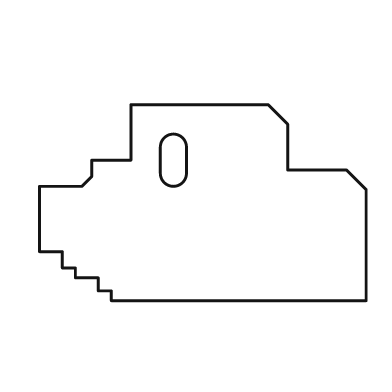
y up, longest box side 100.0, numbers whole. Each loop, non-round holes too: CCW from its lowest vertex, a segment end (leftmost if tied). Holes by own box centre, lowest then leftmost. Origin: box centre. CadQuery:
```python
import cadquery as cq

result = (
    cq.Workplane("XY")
    .moveTo(-28.0, -30.0)
    .lineTo(50.0, -30.0)
    .lineTo(50.0, 4.0)
    .lineTo(44.0, 10.0)
    .lineTo(26.0, 10.0)
    .lineTo(26.0, 24.0)
    .lineTo(20.0, 30.0)
    .lineTo(-22.0, 30.0)
    .lineTo(-22.0, 13.0)
    .lineTo(-34.0, 13.0)
    .lineTo(-34.0, 8.0)
    .lineTo(-37.0, 5.0)
    .lineTo(-50.0, 5.0)
    .lineTo(-50.0, -15.0)
    .lineTo(-43.0, -15.0)
    .lineTo(-43.0, -20.0)
    .lineTo(-39.0, -20.0)
    .lineTo(-39.0, -23.0)
    .lineTo(-32.0, -23.0)
    .lineTo(-32.0, -27.0)
    .lineTo(-28.0, -27.0)
    .close()
    .moveTo(-13.0, 9.0)
    .threePointArc((-9.0, 5.0), (-5.0, 9.0))
    .lineTo(-5.0, 17.0)
    .threePointArc((-9.0, 21.0), (-13.0, 17.0))
    .close()
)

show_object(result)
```